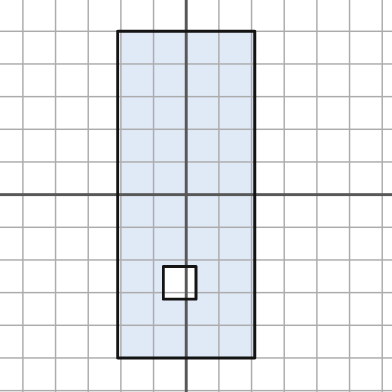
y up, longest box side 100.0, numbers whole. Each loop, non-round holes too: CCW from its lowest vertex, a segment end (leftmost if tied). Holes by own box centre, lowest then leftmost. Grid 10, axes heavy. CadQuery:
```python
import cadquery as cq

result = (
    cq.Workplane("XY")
    .moveTo(-21.0, -50.0)
    .lineTo(21.0, -50.0)
    .lineTo(21.0, 50.0)
    .lineTo(-21.0, 50.0)
    .close()
    .moveTo(-7.0, -32.0)
    .lineTo(3.0, -32.0)
    .lineTo(3.0, -22.0)
    .lineTo(-7.0, -22.0)
    .close()
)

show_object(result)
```